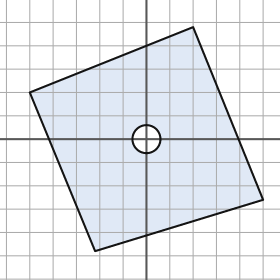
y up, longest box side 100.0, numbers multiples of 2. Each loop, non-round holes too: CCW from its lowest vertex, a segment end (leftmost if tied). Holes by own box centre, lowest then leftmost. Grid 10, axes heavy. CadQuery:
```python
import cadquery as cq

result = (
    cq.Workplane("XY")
    .moveTo(-22.0, -48.0)
    .lineTo(50.0, -26.0)
    .lineTo(20.0, 48.0)
    .lineTo(-50.0, 20.0)
    .close()
    .moveTo(0.0, 0.0)
    .circle(6.0)
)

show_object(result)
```